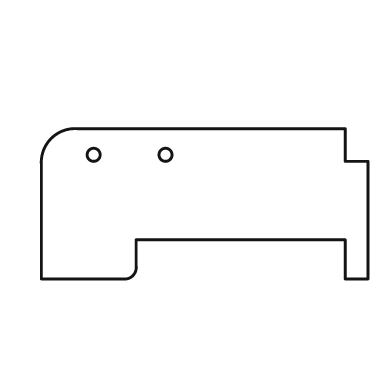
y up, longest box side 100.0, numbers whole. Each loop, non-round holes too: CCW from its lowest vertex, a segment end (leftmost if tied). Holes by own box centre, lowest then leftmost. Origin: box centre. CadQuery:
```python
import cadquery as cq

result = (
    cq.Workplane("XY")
    .moveTo(-50.0, -23.0)
    .lineTo(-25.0, -23.0)
    .threePointArc((-22.0, -22.0), (-21.0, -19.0))
    .lineTo(-21.0, -11.0)
    .lineTo(43.0, -11.0)
    .lineTo(43.0, -23.0)
    .lineTo(50.0, -23.0)
    .lineTo(50.0, 13.0)
    .lineTo(43.0, 13.0)
    .lineTo(43.0, 23.0)
    .lineTo(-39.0, 23.0)
    .threePointArc((-47.0, 20.0), (-50.0, 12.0))
    .close()
    .moveTo(-34.0, 15.0)
    .circle(2.0)
    .moveTo(-12.0, 15.0)
    .circle(2.0)
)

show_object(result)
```